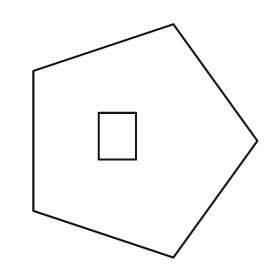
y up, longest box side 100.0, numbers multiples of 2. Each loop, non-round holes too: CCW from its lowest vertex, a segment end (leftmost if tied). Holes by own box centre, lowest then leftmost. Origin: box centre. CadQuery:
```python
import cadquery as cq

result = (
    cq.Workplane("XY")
    .moveTo(12.0, -50.0)
    .lineTo(48.0, 0.0)
    .lineTo(12.0, 50.0)
    .lineTo(-48.0, 30.0)
    .lineTo(-48.0, -30.0)
    .close()
    .moveTo(-20.0, -8.0)
    .lineTo(-4.0, -8.0)
    .lineTo(-4.0, 12.0)
    .lineTo(-20.0, 12.0)
    .close()
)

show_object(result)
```